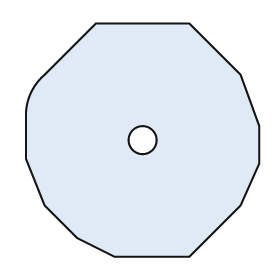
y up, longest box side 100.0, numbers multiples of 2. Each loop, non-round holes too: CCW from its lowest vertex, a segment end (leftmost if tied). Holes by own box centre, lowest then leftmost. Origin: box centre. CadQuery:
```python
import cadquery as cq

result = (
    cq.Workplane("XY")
    .moveTo(-12.0, -50.0)
    .lineTo(20.0, -50.0)
    .lineTo(42.0, -28.0)
    .lineTo(50.0, -10.0)
    .lineTo(50.0, 6.0)
    .lineTo(42.0, 28.0)
    .lineTo(20.0, 50.0)
    .lineTo(-20.0, 50.0)
    .lineTo(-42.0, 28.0)
    .threePointArc((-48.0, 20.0), (-50.0, 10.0))
    .lineTo(-50.0, -8.0)
    .lineTo(-42.0, -28.0)
    .lineTo(-28.0, -42.0)
    .close()
    .moveTo(0.0, 0.0)
    .circle(6.0)
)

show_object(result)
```